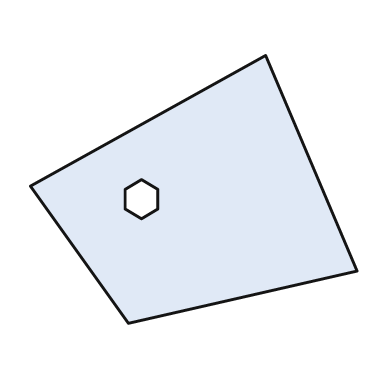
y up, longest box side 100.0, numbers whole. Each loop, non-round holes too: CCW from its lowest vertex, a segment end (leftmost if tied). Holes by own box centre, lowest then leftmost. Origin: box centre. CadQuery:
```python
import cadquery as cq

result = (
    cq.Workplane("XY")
    .moveTo(-20.0, -41.0)
    .lineTo(50.0, -25.0)
    .lineTo(22.0, 41.0)
    .lineTo(-50.0, 1.0)
    .close()
    .moveTo(-16.0, -9.0)
    .lineTo(-11.0, -6.0)
    .lineTo(-11.0, 0.0)
    .lineTo(-16.0, 3.0)
    .lineTo(-21.0, 0.0)
    .lineTo(-21.0, -6.0)
    .close()
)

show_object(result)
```